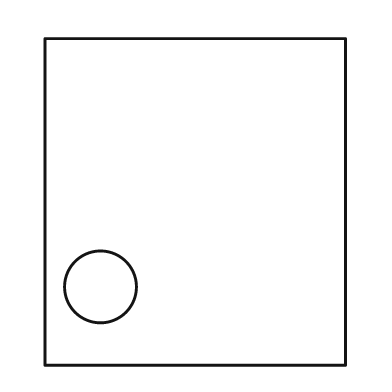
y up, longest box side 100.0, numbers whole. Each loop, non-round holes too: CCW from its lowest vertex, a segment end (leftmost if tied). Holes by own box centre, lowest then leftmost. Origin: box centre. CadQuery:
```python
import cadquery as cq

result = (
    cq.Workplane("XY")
    .moveTo(-46.0, -50.0)
    .lineTo(46.0, -50.0)
    .lineTo(46.0, 50.0)
    .lineTo(-46.0, 50.0)
    .close()
    .moveTo(-29.0, -26.0)
    .circle(11.0)
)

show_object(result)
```